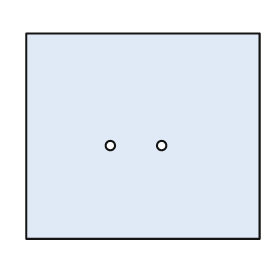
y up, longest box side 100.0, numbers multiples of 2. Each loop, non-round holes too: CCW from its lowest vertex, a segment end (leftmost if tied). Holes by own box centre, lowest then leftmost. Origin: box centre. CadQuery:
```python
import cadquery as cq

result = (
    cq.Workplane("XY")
    .moveTo(-50.0, -44.0)
    .lineTo(50.0, -44.0)
    .lineTo(50.0, 44.0)
    .lineTo(-50.0, 44.0)
    .close()
    .moveTo(-14.0, -4.0)
    .circle(2.0)
    .moveTo(8.0, -4.0)
    .circle(2.0)
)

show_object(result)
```